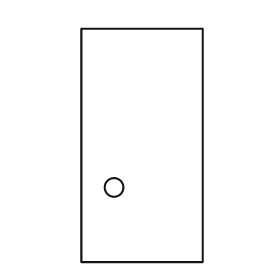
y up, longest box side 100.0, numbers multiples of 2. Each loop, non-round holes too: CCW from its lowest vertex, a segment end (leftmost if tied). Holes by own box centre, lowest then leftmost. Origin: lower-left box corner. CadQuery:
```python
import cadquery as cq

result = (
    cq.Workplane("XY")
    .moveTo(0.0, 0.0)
    .lineTo(52.0, 0.0)
    .lineTo(52.0, 100.0)
    .lineTo(0.0, 100.0)
    .close()
    .moveTo(14.0, 32.0)
    .circle(4.0)
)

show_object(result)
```